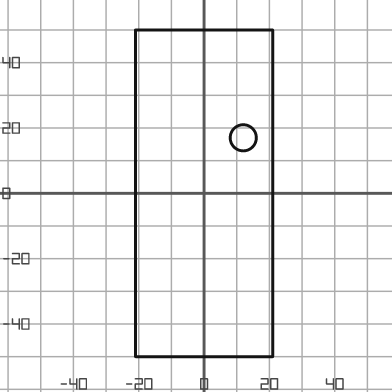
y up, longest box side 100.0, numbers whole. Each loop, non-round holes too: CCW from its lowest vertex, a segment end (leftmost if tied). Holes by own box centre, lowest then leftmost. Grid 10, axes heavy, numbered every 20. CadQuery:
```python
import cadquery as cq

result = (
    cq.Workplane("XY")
    .moveTo(-21.0, -50.0)
    .lineTo(21.0, -50.0)
    .lineTo(21.0, 50.0)
    .lineTo(-21.0, 50.0)
    .close()
    .moveTo(12.0, 17.0)
    .circle(4.0)
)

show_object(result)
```